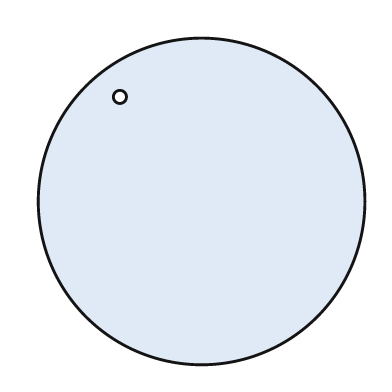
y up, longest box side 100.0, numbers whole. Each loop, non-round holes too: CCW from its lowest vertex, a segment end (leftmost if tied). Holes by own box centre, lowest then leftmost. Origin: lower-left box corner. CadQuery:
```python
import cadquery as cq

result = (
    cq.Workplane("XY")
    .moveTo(50.0, 50.0)
    .circle(50.0)
    .moveTo(25.0, 82.0)
    .circle(2.0)
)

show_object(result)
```